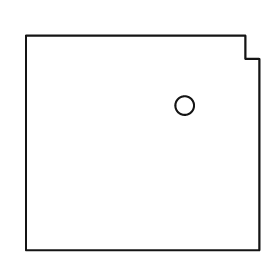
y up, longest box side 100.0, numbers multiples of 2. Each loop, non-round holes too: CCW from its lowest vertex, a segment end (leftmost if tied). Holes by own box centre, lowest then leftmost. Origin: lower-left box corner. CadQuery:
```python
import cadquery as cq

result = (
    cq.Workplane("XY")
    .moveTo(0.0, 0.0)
    .lineTo(100.0, 0.0)
    .lineTo(100.0, 82.0)
    .lineTo(94.0, 82.0)
    .lineTo(94.0, 92.0)
    .lineTo(0.0, 92.0)
    .close()
    .moveTo(68.0, 62.0)
    .circle(4.0)
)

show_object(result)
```